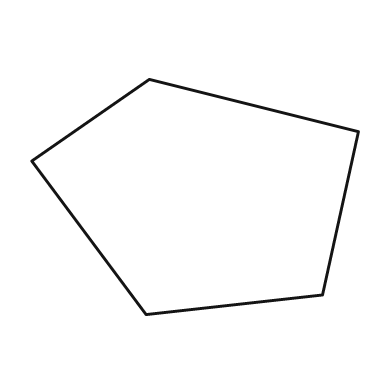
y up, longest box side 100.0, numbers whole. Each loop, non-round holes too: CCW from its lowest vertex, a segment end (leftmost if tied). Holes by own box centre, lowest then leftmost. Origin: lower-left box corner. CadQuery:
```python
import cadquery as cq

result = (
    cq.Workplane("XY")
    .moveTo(35.0, 0.0)
    .lineTo(89.0, 6.0)
    .lineTo(100.0, 56.0)
    .lineTo(36.0, 72.0)
    .lineTo(0.0, 47.0)
    .close()
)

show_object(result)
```